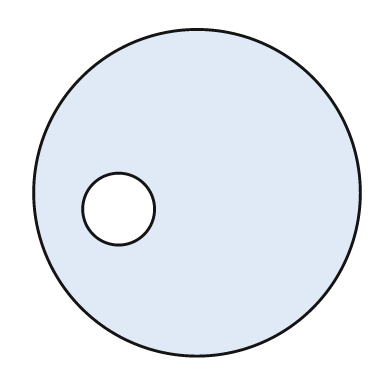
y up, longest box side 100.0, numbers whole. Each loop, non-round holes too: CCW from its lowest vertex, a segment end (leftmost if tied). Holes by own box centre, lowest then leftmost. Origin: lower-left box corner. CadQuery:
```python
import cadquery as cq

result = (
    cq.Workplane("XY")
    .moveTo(50.0, 50.0)
    .circle(50.0)
    .moveTo(26.0, 45.0)
    .circle(11.0)
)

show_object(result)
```